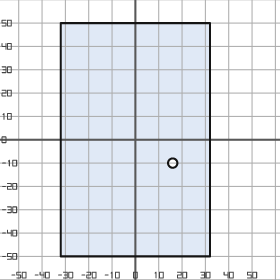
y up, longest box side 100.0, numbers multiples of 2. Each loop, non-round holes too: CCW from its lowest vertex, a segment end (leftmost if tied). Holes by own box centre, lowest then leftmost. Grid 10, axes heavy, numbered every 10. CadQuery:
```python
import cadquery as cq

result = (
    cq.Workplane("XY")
    .moveTo(-32.0, -50.0)
    .lineTo(32.0, -50.0)
    .lineTo(32.0, 50.0)
    .lineTo(-32.0, 50.0)
    .close()
    .moveTo(16.0, -10.0)
    .circle(2.0)
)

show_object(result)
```